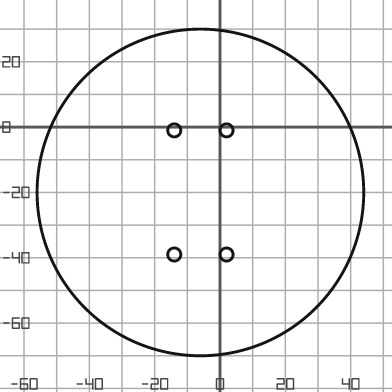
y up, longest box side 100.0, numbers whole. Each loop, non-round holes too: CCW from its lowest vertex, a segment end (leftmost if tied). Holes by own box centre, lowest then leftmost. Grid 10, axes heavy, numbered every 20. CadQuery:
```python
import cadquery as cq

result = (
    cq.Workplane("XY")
    .moveTo(-6.0, -20.0)
    .circle(50.0)
    .moveTo(-14.0, -39.0)
    .circle(2.0)
    .moveTo(2.0, -39.0)
    .circle(2.0)
    .moveTo(-14.0, -1.0)
    .circle(2.0)
    .moveTo(2.0, -1.0)
    .circle(2.0)
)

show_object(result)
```